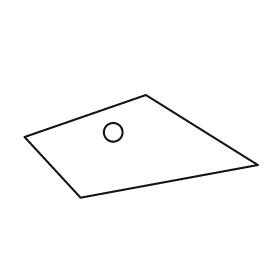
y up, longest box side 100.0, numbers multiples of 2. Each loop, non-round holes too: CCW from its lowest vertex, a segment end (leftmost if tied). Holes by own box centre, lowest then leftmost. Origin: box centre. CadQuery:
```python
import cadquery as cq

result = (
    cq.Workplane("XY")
    .moveTo(-26.0, -22.0)
    .lineTo(50.0, -8.0)
    .lineTo(2.0, 22.0)
    .lineTo(-50.0, 4.0)
    .close()
    .moveTo(-12.0, 6.0)
    .circle(4.0)
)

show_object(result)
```